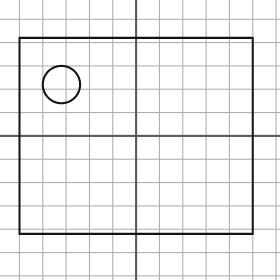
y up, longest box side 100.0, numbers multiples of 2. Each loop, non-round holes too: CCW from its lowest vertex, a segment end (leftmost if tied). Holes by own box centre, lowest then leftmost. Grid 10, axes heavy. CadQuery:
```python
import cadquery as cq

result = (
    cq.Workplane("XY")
    .moveTo(-50.0, -42.0)
    .lineTo(50.0, -42.0)
    .lineTo(50.0, 42.0)
    .lineTo(-50.0, 42.0)
    .close()
    .moveTo(-32.0, 22.0)
    .circle(8.0)
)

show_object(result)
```